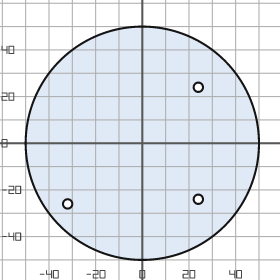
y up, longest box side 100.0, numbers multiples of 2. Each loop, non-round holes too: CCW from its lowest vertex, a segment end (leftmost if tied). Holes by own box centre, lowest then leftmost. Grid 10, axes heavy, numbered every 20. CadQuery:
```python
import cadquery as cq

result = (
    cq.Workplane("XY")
    .moveTo(0.0, 0.0)
    .circle(50.0)
    .moveTo(-32.0, -26.0)
    .circle(2.0)
    .moveTo(24.0, -24.0)
    .circle(2.0)
    .moveTo(24.0, 24.0)
    .circle(2.0)
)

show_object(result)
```